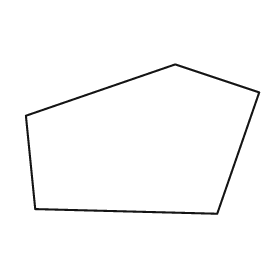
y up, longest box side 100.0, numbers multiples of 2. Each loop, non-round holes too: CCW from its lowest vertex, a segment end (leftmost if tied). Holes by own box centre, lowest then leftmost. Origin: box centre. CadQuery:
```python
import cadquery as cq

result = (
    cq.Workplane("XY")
    .moveTo(32.0, -32.0)
    .lineTo(50.0, 20.0)
    .lineTo(14.0, 32.0)
    .lineTo(-50.0, 10.0)
    .lineTo(-46.0, -30.0)
    .close()
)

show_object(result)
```